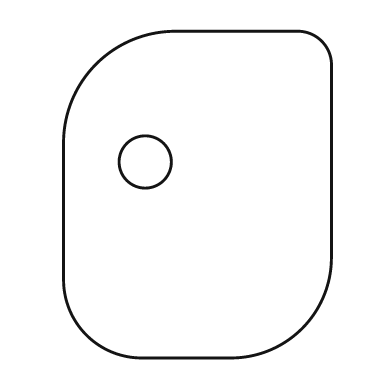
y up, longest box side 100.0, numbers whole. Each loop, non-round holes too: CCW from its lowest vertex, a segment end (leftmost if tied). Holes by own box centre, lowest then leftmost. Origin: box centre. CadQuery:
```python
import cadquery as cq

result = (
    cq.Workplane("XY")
    .moveTo(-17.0, -50.0)
    .lineTo(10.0, -50.0)
    .threePointArc((32.0, -41.0), (41.0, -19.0))
    .lineTo(41.0, 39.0)
    .threePointArc((38.0, 47.0), (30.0, 50.0))
    .lineTo(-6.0, 50.0)
    .threePointArc((-31.0, 40.0), (-41.0, 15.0))
    .lineTo(-41.0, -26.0)
    .threePointArc((-34.0, -43.0), (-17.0, -50.0))
    .close()
    .moveTo(-16.0, 10.0)
    .circle(8.0)
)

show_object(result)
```